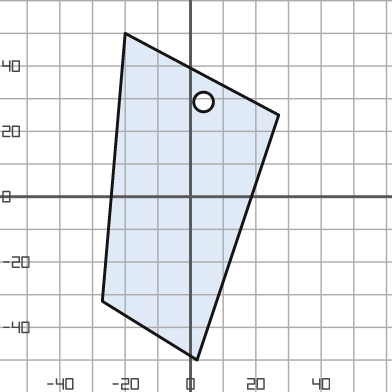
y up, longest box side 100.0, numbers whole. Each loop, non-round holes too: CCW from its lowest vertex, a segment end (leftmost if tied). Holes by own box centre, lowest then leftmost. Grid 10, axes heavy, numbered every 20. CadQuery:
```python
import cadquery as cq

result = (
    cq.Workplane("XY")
    .moveTo(2.0, -50.0)
    .lineTo(27.0, 25.0)
    .lineTo(-20.0, 50.0)
    .lineTo(-27.0, -32.0)
    .close()
    .moveTo(4.0, 29.0)
    .circle(3.0)
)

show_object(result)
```